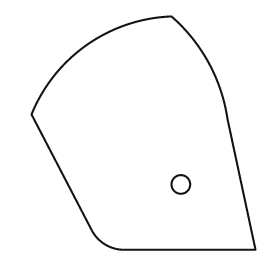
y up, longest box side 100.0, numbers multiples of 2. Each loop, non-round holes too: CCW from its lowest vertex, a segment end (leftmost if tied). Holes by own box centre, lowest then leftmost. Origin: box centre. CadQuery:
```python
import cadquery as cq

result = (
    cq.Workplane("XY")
    .moveTo(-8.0, -50.0)
    .lineTo(48.0, -50.0)
    .lineTo(36.0, 6.0)
    .threePointArc((28.0, 30.0), (12.0, 50.0))
    .threePointArc((-24.0, 38.0), (-48.0, 8.0))
    .lineTo(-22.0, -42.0)
    .threePointArc((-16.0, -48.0), (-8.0, -50.0))
    .close()
    .moveTo(16.0, -22.0)
    .circle(4.0)
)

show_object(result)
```